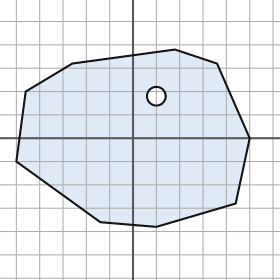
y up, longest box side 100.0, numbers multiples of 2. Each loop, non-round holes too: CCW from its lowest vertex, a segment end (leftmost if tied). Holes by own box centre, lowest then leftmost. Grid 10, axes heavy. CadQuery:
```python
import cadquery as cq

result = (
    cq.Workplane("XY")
    .moveTo(10.0, -38.0)
    .lineTo(44.0, -28.0)
    .lineTo(50.0, 0.0)
    .lineTo(36.0, 32.0)
    .lineTo(18.0, 38.0)
    .lineTo(-26.0, 32.0)
    .lineTo(-46.0, 20.0)
    .lineTo(-50.0, -10.0)
    .lineTo(-14.0, -36.0)
    .close()
    .moveTo(10.0, 18.0)
    .circle(4.0)
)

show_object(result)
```